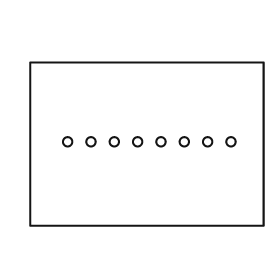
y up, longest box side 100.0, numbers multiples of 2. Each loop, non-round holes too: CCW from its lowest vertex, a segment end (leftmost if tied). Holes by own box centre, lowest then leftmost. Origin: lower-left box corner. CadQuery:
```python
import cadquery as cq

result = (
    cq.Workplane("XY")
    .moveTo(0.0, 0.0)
    .lineTo(100.0, 0.0)
    .lineTo(100.0, 70.0)
    .lineTo(0.0, 70.0)
    .close()
    .moveTo(16.0, 36.0)
    .circle(2.0)
    .moveTo(26.0, 36.0)
    .circle(2.0)
    .moveTo(36.0, 36.0)
    .circle(2.0)
    .moveTo(46.0, 36.0)
    .circle(2.0)
    .moveTo(56.0, 36.0)
    .circle(2.0)
    .moveTo(66.0, 36.0)
    .circle(2.0)
    .moveTo(76.0, 36.0)
    .circle(2.0)
    .moveTo(86.0, 36.0)
    .circle(2.0)
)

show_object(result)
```